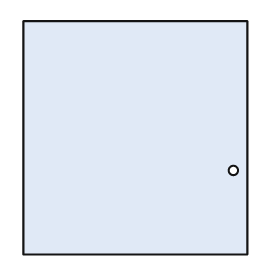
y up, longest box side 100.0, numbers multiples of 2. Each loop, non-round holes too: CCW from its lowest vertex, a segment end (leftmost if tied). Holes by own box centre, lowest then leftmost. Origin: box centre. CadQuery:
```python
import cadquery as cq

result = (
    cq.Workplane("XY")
    .moveTo(-48.0, -50.0)
    .lineTo(48.0, -50.0)
    .lineTo(48.0, 50.0)
    .lineTo(-48.0, 50.0)
    .close()
    .moveTo(42.0, -14.0)
    .circle(2.0)
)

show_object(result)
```